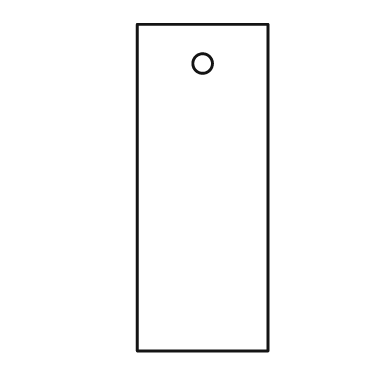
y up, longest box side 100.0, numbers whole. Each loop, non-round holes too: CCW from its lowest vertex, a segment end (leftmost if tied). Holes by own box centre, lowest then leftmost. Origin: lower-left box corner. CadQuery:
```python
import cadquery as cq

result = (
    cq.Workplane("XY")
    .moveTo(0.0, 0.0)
    .lineTo(40.0, 0.0)
    .lineTo(40.0, 100.0)
    .lineTo(0.0, 100.0)
    .close()
    .moveTo(20.0, 88.0)
    .circle(3.0)
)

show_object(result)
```